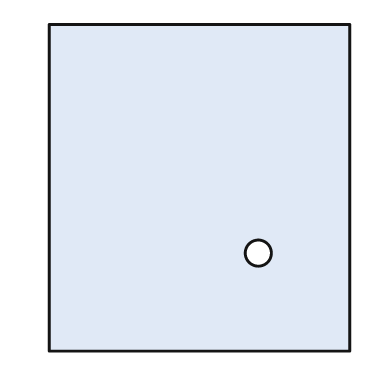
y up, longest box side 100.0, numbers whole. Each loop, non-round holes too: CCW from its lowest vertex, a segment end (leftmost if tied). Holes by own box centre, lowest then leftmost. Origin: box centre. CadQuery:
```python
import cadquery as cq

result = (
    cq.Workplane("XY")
    .moveTo(-46.0, -50.0)
    .lineTo(46.0, -50.0)
    .lineTo(46.0, 50.0)
    .lineTo(-46.0, 50.0)
    .close()
    .moveTo(18.0, -20.0)
    .circle(4.0)
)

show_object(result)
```